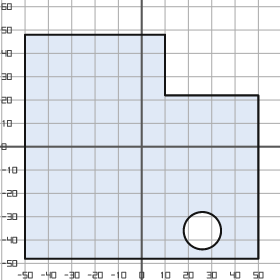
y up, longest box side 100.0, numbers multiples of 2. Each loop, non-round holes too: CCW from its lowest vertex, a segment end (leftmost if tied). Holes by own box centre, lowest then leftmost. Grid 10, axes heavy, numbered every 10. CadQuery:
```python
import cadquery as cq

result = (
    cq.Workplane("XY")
    .moveTo(-50.0, -48.0)
    .lineTo(50.0, -48.0)
    .lineTo(50.0, 22.0)
    .lineTo(10.0, 22.0)
    .lineTo(10.0, 48.0)
    .lineTo(-50.0, 48.0)
    .close()
    .moveTo(26.0, -36.0)
    .circle(8.0)
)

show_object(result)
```